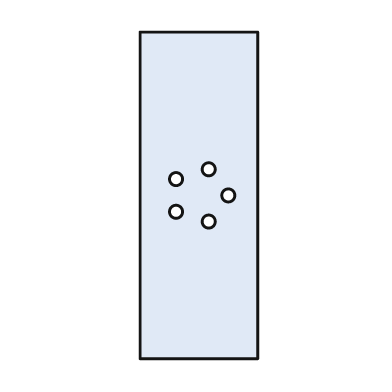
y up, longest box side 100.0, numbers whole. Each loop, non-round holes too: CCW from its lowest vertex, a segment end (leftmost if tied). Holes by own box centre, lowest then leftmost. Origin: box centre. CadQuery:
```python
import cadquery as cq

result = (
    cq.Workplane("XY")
    .moveTo(-18.0, -50.0)
    .lineTo(18.0, -50.0)
    .lineTo(18.0, 50.0)
    .lineTo(-18.0, 50.0)
    .close()
    .moveTo(3.0, -8.0)
    .circle(2.0)
    .moveTo(-7.0, -5.0)
    .circle(2.0)
    .moveTo(9.0, 0.0)
    .circle(2.0)
    .moveTo(-7.0, 5.0)
    .circle(2.0)
    .moveTo(3.0, 8.0)
    .circle(2.0)
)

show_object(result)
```